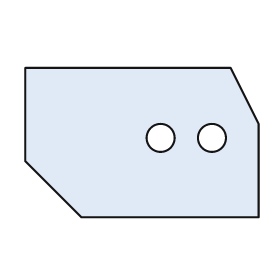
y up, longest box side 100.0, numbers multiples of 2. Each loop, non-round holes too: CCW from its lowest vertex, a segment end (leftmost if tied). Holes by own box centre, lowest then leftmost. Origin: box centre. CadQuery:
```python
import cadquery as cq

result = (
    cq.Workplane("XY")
    .moveTo(-26.0, -32.0)
    .lineTo(50.0, -32.0)
    .lineTo(50.0, 8.0)
    .lineTo(38.0, 32.0)
    .lineTo(-50.0, 32.0)
    .lineTo(-50.0, -8.0)
    .close()
    .moveTo(8.0, 2.0)
    .circle(6.0)
    .moveTo(30.0, 2.0)
    .circle(6.0)
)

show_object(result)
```